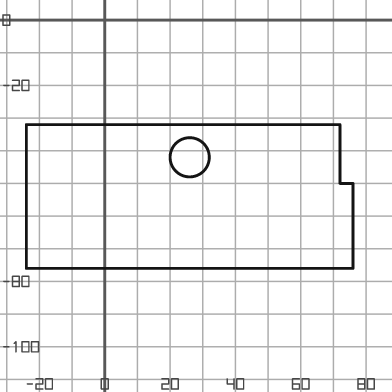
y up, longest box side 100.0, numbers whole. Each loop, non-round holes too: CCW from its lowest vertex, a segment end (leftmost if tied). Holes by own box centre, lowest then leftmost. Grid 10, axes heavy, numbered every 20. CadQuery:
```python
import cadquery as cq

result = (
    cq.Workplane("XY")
    .moveTo(-24.0, -76.0)
    .lineTo(76.0, -76.0)
    .lineTo(76.0, -50.0)
    .lineTo(72.0, -50.0)
    .lineTo(72.0, -32.0)
    .lineTo(-24.0, -32.0)
    .close()
    .moveTo(26.0, -42.0)
    .circle(6.0)
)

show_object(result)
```